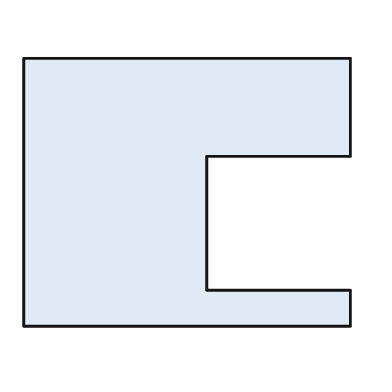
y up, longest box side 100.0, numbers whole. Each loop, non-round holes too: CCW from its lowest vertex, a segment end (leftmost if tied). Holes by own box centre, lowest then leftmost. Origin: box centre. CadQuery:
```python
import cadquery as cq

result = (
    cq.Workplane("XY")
    .moveTo(-50.0, -41.0)
    .lineTo(50.0, -41.0)
    .lineTo(50.0, -30.0)
    .lineTo(6.0, -30.0)
    .lineTo(6.0, 11.0)
    .lineTo(50.0, 11.0)
    .lineTo(50.0, 41.0)
    .lineTo(-50.0, 41.0)
    .close()
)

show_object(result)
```